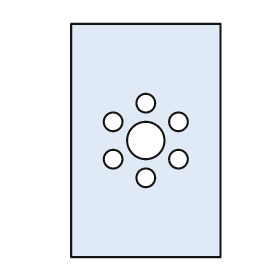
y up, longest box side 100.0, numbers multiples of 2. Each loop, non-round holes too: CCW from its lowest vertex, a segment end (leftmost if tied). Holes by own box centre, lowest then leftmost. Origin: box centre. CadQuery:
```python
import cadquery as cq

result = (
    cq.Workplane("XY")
    .moveTo(-32.0, -50.0)
    .lineTo(32.0, -50.0)
    .lineTo(32.0, 50.0)
    .lineTo(-32.0, 50.0)
    .close()
    .moveTo(0.0, -16.0)
    .circle(4.0)
    .moveTo(-14.0, -8.0)
    .circle(4.0)
    .moveTo(14.0, -8.0)
    .circle(4.0)
    .moveTo(0.0, 0.0)
    .circle(8.0)
    .moveTo(-14.0, 8.0)
    .circle(4.0)
    .moveTo(14.0, 8.0)
    .circle(4.0)
    .moveTo(0.0, 16.0)
    .circle(4.0)
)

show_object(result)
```